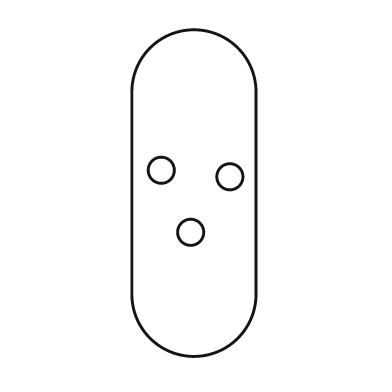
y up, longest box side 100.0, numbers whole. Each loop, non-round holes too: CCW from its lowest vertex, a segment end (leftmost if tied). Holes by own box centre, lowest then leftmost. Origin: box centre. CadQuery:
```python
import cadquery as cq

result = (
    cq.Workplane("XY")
    .moveTo(-19.0, -31.0)
    .threePointArc((0.0, -50.0), (19.0, -31.0))
    .lineTo(19.0, 31.0)
    .threePointArc((0.0, 50.0), (-19.0, 31.0))
    .close()
    .moveTo(-1.0, -12.0)
    .circle(4.0)
    .moveTo(11.0, 5.0)
    .circle(4.0)
    .moveTo(-10.0, 7.0)
    .circle(4.0)
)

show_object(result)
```